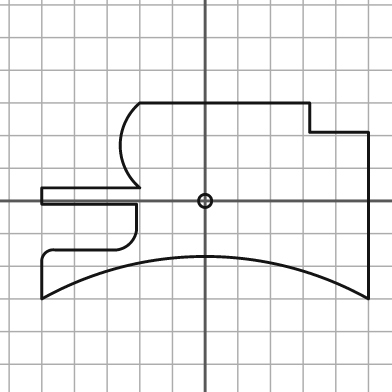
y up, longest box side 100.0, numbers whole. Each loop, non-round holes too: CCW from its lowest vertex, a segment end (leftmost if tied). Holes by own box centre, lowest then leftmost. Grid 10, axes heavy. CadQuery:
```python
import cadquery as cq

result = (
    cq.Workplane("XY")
    .moveTo(-50.0, -30.0)
    .threePointArc((0.0, -17.0), (50.0, -30.0))
    .lineTo(50.0, 21.0)
    .lineTo(32.0, 21.0)
    .lineTo(32.0, 30.0)
    .lineTo(-20.0, 30.0)
    .threePointArc((-26.0, 17.0), (-20.0, 4.0))
    .lineTo(-50.0, 4.0)
    .lineTo(-50.0, -1.0)
    .lineTo(-21.0, -1.0)
    .lineTo(-21.0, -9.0)
    .threePointArc((-23.0, -13.0), (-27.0, -15.0))
    .lineTo(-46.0, -15.0)
    .threePointArc((-49.0, -16.0), (-50.0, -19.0))
    .close()
    .moveTo(0.0, 0.0)
    .circle(2.0)
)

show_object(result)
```